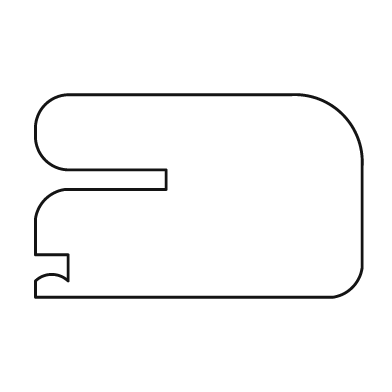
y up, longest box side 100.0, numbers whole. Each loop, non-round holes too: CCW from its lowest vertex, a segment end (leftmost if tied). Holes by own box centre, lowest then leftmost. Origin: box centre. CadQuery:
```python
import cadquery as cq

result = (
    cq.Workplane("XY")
    .moveTo(-50.0, -31.0)
    .lineTo(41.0, -31.0)
    .threePointArc((47.0, -28.0), (50.0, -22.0))
    .lineTo(50.0, 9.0)
    .threePointArc((44.0, 25.0), (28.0, 31.0))
    .lineTo(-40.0, 31.0)
    .threePointArc((-47.0, 28.0), (-50.0, 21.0))
    .lineTo(-50.0, 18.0)
    .threePointArc((-47.0, 11.0), (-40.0, 8.0))
    .lineTo(-10.0, 8.0)
    .lineTo(-10.0, 2.0)
    .lineTo(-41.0, 2.0)
    .threePointArc((-47.0, -1.0), (-50.0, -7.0))
    .lineTo(-50.0, -18.0)
    .lineTo(-40.0, -18.0)
    .lineTo(-40.0, -26.0)
    .threePointArc((-45.0, -24.0), (-50.0, -26.0))
    .close()
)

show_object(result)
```